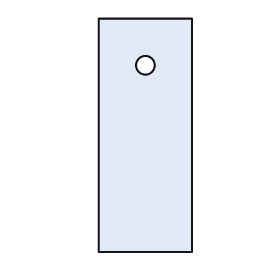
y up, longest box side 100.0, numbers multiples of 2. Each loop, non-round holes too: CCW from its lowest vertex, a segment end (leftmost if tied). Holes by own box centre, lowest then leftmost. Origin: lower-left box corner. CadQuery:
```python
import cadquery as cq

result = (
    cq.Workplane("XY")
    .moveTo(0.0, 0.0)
    .lineTo(40.0, 0.0)
    .lineTo(40.0, 100.0)
    .lineTo(0.0, 100.0)
    .close()
    .moveTo(20.0, 80.0)
    .circle(4.0)
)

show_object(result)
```